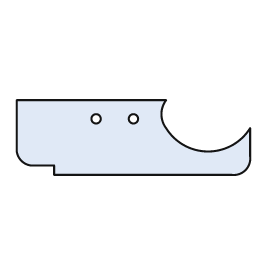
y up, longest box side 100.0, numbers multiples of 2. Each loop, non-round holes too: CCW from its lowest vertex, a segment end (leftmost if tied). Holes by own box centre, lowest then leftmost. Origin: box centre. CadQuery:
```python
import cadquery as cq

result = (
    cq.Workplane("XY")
    .moveTo(-34.0, -16.0)
    .lineTo(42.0, -16.0)
    .threePointArc((48.0, -14.0), (50.0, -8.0))
    .lineTo(50.0, 4.0)
    .threePointArc((32.0, -6.0), (14.0, 4.0))
    .threePointArc((12.0, 10.0), (14.0, 16.0))
    .lineTo(-50.0, 16.0)
    .lineTo(-50.0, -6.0)
    .threePointArc((-48.0, -10.0), (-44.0, -12.0))
    .lineTo(-34.0, -12.0)
    .close()
    .moveTo(-16.0, 8.0)
    .circle(2.0)
    .moveTo(0.0, 8.0)
    .circle(2.0)
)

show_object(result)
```